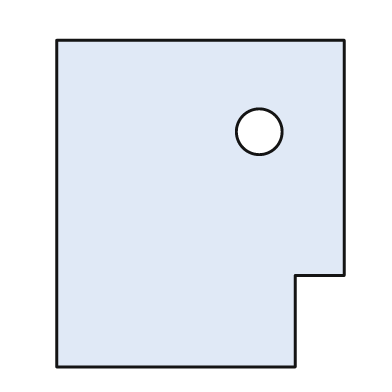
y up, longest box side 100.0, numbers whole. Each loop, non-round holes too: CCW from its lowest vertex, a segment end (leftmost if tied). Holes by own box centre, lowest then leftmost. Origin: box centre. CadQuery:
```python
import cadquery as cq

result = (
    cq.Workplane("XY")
    .moveTo(-44.0, -50.0)
    .lineTo(29.0, -50.0)
    .lineTo(29.0, -22.0)
    .lineTo(44.0, -22.0)
    .lineTo(44.0, 50.0)
    .lineTo(-44.0, 50.0)
    .close()
    .moveTo(18.0, 22.0)
    .circle(7.0)
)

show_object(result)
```